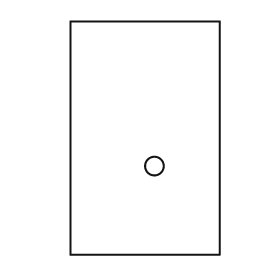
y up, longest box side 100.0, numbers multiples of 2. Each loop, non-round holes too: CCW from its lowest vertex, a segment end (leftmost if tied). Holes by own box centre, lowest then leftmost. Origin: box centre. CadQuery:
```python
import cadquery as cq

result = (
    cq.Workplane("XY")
    .moveTo(-32.0, -50.0)
    .lineTo(32.0, -50.0)
    .lineTo(32.0, 50.0)
    .lineTo(-32.0, 50.0)
    .close()
    .moveTo(4.0, -12.0)
    .circle(4.0)
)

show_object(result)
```